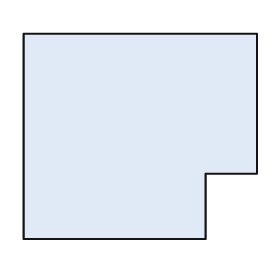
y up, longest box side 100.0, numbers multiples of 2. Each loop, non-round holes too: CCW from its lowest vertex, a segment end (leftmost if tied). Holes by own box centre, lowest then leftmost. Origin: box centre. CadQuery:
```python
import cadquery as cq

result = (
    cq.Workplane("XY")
    .moveTo(-50.0, -44.0)
    .lineTo(28.0, -44.0)
    .lineTo(28.0, -16.0)
    .lineTo(50.0, -16.0)
    .lineTo(50.0, 44.0)
    .lineTo(-50.0, 44.0)
    .close()
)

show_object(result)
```